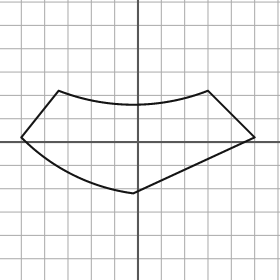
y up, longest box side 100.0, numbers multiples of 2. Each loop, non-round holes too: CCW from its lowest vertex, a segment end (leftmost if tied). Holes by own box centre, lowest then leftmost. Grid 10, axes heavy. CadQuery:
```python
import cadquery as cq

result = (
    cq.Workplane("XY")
    .moveTo(-2.0, -22.0)
    .lineTo(50.0, 2.0)
    .lineTo(30.0, 22.0)
    .threePointArc((-2.0, 16.0), (-34.0, 22.0))
    .lineTo(-50.0, 2.0)
    .threePointArc((-28.0, -14.0), (-2.0, -22.0))
    .close()
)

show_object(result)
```